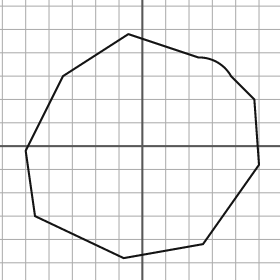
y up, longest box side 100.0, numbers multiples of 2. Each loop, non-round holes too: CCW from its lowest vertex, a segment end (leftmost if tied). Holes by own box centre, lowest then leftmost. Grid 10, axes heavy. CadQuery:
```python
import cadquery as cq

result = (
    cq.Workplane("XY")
    .moveTo(-8.0, -48.0)
    .lineTo(26.0, -42.0)
    .lineTo(50.0, -8.0)
    .lineTo(48.0, 20.0)
    .lineTo(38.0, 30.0)
    .threePointArc((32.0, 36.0), (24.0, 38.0))
    .lineTo(-6.0, 48.0)
    .lineTo(-34.0, 30.0)
    .lineTo(-50.0, -2.0)
    .lineTo(-46.0, -30.0)
    .close()
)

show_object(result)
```